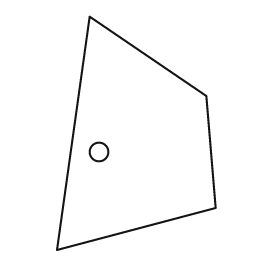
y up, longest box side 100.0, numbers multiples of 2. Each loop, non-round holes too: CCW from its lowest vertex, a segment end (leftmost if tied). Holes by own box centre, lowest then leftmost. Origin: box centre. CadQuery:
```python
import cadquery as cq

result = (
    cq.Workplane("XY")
    .moveTo(-34.0, -50.0)
    .lineTo(34.0, -32.0)
    .lineTo(30.0, 16.0)
    .lineTo(-20.0, 50.0)
    .close()
    .moveTo(-16.0, -8.0)
    .circle(4.0)
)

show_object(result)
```